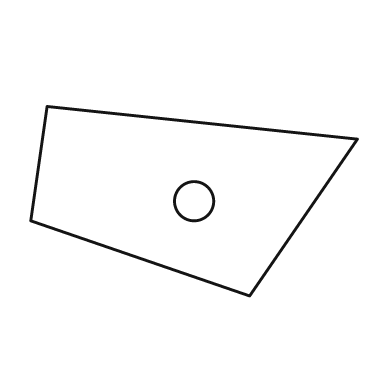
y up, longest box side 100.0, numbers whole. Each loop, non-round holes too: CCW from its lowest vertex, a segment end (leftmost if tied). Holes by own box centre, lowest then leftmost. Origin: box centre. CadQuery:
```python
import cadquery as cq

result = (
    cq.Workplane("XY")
    .moveTo(17.0, -29.0)
    .lineTo(50.0, 19.0)
    .lineTo(-45.0, 29.0)
    .lineTo(-50.0, -6.0)
    .close()
    .moveTo(0.0, 0.0)
    .circle(6.0)
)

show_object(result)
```